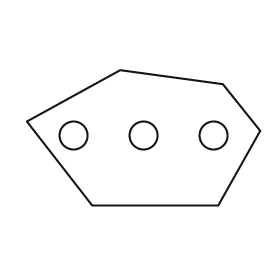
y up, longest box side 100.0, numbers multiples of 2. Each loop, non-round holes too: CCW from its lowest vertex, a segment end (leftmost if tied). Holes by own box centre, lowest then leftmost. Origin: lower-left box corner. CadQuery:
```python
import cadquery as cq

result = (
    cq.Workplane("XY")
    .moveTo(28.0, 0.0)
    .lineTo(82.0, 0.0)
    .lineTo(100.0, 32.0)
    .lineTo(84.0, 52.0)
    .lineTo(40.0, 58.0)
    .lineTo(0.0, 36.0)
    .close()
    .moveTo(20.0, 30.0)
    .circle(6.0)
    .moveTo(50.0, 30.0)
    .circle(6.0)
    .moveTo(80.0, 30.0)
    .circle(6.0)
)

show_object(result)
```